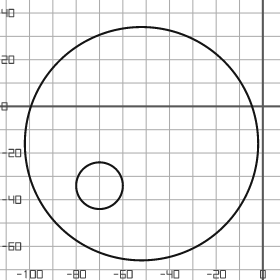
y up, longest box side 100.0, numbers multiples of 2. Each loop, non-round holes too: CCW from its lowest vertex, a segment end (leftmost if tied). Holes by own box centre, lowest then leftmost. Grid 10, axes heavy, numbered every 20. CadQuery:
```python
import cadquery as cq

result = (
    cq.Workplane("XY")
    .moveTo(-52.0, -16.0)
    .circle(50.0)
    .moveTo(-70.0, -34.0)
    .circle(10.0)
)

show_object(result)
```